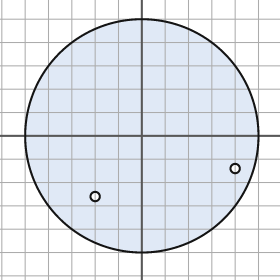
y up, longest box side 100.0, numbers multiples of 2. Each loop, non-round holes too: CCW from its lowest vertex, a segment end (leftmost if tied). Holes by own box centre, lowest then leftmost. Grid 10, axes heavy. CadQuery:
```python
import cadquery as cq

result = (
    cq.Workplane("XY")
    .moveTo(0.0, 0.0)
    .circle(50.0)
    .moveTo(-20.0, -26.0)
    .circle(2.0)
    .moveTo(40.0, -14.0)
    .circle(2.0)
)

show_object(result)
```